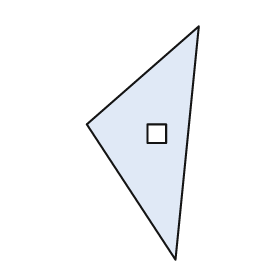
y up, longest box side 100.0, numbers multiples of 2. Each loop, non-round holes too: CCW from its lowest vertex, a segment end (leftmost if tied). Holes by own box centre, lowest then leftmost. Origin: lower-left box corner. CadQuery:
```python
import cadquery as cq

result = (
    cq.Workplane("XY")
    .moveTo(38.0, 0.0)
    .lineTo(48.0, 100.0)
    .lineTo(0.0, 58.0)
    .close()
    .moveTo(26.0, 50.0)
    .lineTo(34.0, 50.0)
    .lineTo(34.0, 58.0)
    .lineTo(26.0, 58.0)
    .close()
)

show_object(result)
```